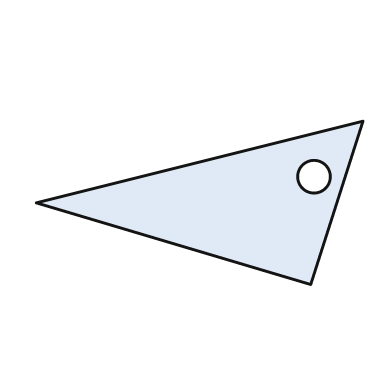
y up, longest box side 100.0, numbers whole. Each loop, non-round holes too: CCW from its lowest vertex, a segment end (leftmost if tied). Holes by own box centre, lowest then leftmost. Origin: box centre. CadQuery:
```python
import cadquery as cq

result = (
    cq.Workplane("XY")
    .moveTo(34.0, -25.0)
    .lineTo(50.0, 25.0)
    .lineTo(-50.0, 0.0)
    .close()
    .moveTo(35.0, 8.0)
    .circle(5.0)
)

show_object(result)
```